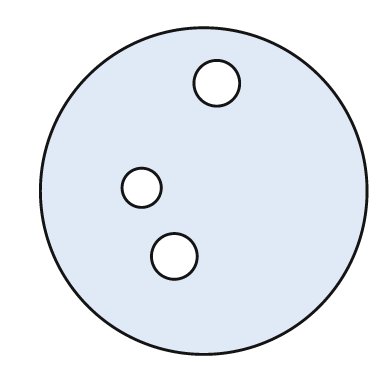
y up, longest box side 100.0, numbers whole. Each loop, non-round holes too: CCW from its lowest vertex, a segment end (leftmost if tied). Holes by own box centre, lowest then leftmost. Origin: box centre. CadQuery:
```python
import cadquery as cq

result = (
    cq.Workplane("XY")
    .moveTo(0.0, 0.0)
    .circle(50.0)
    .moveTo(-9.0, -20.0)
    .circle(7.0)
    .moveTo(-19.0, 1.0)
    .circle(6.0)
    .moveTo(4.0, 33.0)
    .circle(7.0)
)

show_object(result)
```